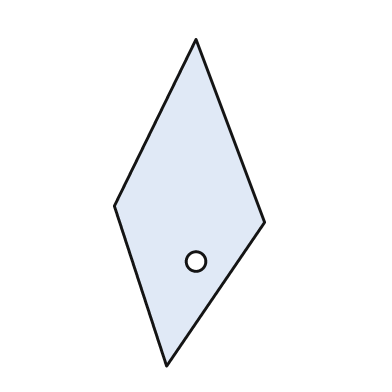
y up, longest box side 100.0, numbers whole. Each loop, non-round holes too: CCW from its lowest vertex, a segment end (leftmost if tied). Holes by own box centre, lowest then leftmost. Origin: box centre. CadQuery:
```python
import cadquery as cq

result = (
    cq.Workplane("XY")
    .moveTo(-7.0, -50.0)
    .lineTo(23.0, -6.0)
    .lineTo(2.0, 50.0)
    .lineTo(-23.0, -1.0)
    .close()
    .moveTo(2.0, -18.0)
    .circle(3.0)
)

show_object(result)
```